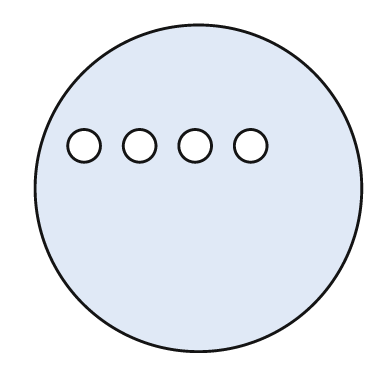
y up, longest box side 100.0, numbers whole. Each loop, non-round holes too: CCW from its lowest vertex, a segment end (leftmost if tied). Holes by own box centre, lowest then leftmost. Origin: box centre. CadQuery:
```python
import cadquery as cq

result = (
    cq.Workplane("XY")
    .moveTo(0.0, 0.0)
    .circle(50.0)
    .moveTo(-35.0, 13.0)
    .circle(5.0)
    .moveTo(-18.0, 13.0)
    .circle(5.0)
    .moveTo(-1.0, 13.0)
    .circle(5.0)
    .moveTo(16.0, 13.0)
    .circle(5.0)
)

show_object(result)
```